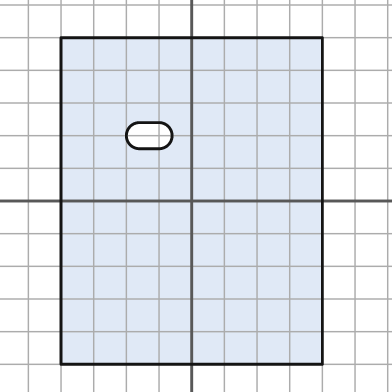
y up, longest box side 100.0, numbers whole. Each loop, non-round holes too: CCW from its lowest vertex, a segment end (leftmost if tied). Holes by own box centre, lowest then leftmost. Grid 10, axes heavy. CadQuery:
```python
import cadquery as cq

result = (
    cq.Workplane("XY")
    .moveTo(-40.0, -50.0)
    .lineTo(40.0, -50.0)
    .lineTo(40.0, 50.0)
    .lineTo(-40.0, 50.0)
    .close()
    .moveTo(-16.0, 16.0)
    .lineTo(-10.0, 16.0)
    .threePointArc((-6.0, 20.0), (-10.0, 24.0))
    .lineTo(-16.0, 24.0)
    .threePointArc((-20.0, 20.0), (-16.0, 16.0))
    .close()
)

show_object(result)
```